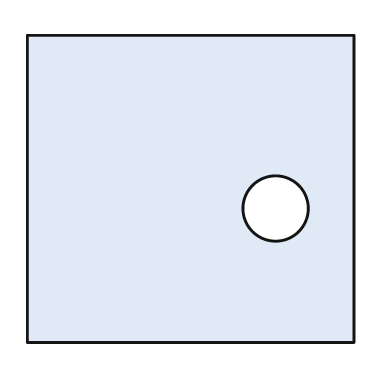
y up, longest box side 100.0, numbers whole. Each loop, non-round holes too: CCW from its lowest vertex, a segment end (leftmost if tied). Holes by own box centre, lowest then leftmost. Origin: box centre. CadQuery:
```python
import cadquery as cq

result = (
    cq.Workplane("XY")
    .moveTo(-50.0, -47.0)
    .lineTo(50.0, -47.0)
    .lineTo(50.0, 47.0)
    .lineTo(-50.0, 47.0)
    .close()
    .moveTo(26.0, -6.0)
    .circle(10.0)
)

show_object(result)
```